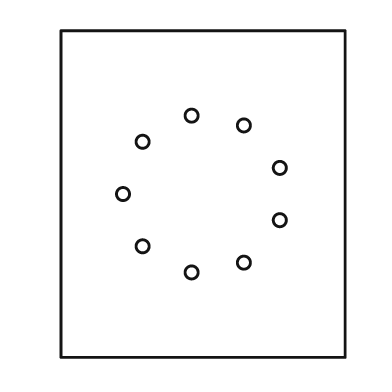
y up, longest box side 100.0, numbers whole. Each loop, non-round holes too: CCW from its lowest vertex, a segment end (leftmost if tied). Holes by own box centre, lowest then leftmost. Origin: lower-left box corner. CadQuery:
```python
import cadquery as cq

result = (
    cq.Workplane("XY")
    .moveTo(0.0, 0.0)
    .lineTo(87.0, 0.0)
    .lineTo(87.0, 100.0)
    .lineTo(0.0, 100.0)
    .close()
    .moveTo(40.0, 26.0)
    .circle(2.0)
    .moveTo(56.0, 29.0)
    .circle(2.0)
    .moveTo(25.0, 34.0)
    .circle(2.0)
    .moveTo(67.0, 42.0)
    .circle(2.0)
    .moveTo(19.0, 50.0)
    .circle(2.0)
    .moveTo(67.0, 58.0)
    .circle(2.0)
    .moveTo(25.0, 66.0)
    .circle(2.0)
    .moveTo(56.0, 71.0)
    .circle(2.0)
    .moveTo(40.0, 74.0)
    .circle(2.0)
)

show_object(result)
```